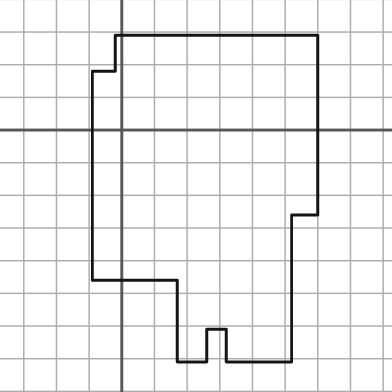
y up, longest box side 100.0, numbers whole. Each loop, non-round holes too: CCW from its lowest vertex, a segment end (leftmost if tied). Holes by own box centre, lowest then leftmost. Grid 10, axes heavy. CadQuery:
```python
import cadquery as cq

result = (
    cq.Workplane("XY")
    .moveTo(17.0, -71.0)
    .lineTo(26.0, -71.0)
    .lineTo(26.0, -61.0)
    .lineTo(32.0, -61.0)
    .lineTo(32.0, -71.0)
    .lineTo(52.0, -71.0)
    .lineTo(52.0, -26.0)
    .lineTo(60.0, -26.0)
    .lineTo(60.0, 29.0)
    .lineTo(-2.0, 29.0)
    .lineTo(-2.0, 18.0)
    .lineTo(-9.0, 18.0)
    .lineTo(-9.0, -46.0)
    .lineTo(17.0, -46.0)
    .close()
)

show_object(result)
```